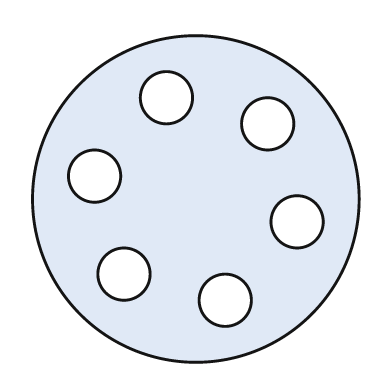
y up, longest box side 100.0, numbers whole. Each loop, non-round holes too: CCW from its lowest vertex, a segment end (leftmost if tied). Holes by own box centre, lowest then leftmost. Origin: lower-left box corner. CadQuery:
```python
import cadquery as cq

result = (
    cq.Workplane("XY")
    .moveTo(50.0, 50.0)
    .circle(50.0)
    .moveTo(59.0, 19.0)
    .circle(8.0)
    .moveTo(28.0, 27.0)
    .circle(8.0)
    .moveTo(81.0, 43.0)
    .circle(8.0)
    .moveTo(19.0, 57.0)
    .circle(8.0)
    .moveTo(72.0, 73.0)
    .circle(8.0)
    .moveTo(41.0, 81.0)
    .circle(8.0)
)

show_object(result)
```